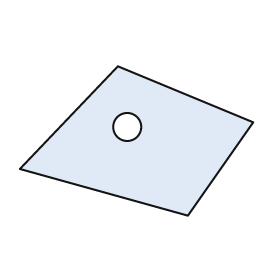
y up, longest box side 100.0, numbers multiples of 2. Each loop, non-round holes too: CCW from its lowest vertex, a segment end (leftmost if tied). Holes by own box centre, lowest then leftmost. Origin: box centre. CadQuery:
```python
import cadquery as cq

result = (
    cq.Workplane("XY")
    .moveTo(22.0, -32.0)
    .lineTo(50.0, 8.0)
    .lineTo(-8.0, 32.0)
    .lineTo(-50.0, -12.0)
    .close()
    .moveTo(-4.0, 6.0)
    .circle(6.0)
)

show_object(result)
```